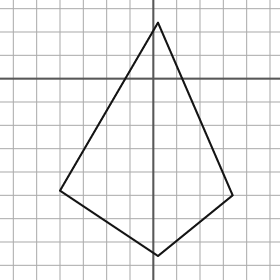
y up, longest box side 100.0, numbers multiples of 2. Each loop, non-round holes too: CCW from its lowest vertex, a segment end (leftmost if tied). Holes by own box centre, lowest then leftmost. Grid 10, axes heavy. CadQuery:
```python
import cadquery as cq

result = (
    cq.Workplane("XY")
    .moveTo(2.0, -76.0)
    .lineTo(34.0, -50.0)
    .lineTo(2.0, 24.0)
    .lineTo(-40.0, -48.0)
    .close()
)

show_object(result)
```